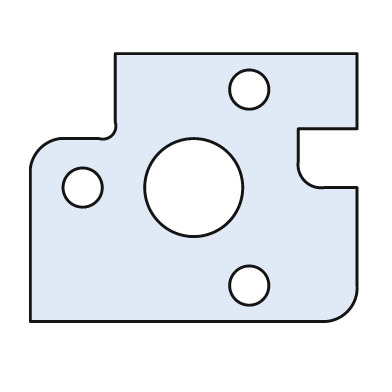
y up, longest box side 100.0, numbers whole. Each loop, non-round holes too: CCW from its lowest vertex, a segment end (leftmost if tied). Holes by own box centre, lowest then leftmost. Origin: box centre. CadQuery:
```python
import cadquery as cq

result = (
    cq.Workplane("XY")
    .moveTo(-50.0, -41.0)
    .lineTo(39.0, -41.0)
    .threePointArc((47.0, -38.0), (50.0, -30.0))
    .lineTo(50.0, 0.0)
    .lineTo(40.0, 0.0)
    .threePointArc((34.0, 2.0), (32.0, 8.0))
    .lineTo(32.0, 18.0)
    .lineTo(50.0, 18.0)
    .lineTo(50.0, 41.0)
    .lineTo(-24.0, 41.0)
    .lineTo(-24.0, 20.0)
    .threePointArc((-25.0, 16.0), (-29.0, 15.0))
    .lineTo(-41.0, 15.0)
    .threePointArc((-47.0, 12.0), (-50.0, 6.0))
    .close()
    .moveTo(17.0, -30.0)
    .circle(6.0)
    .moveTo(-34.0, 0.0)
    .circle(6.0)
    .moveTo(0.0, 0.0)
    .circle(15.0)
    .moveTo(17.0, 30.0)
    .circle(6.0)
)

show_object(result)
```